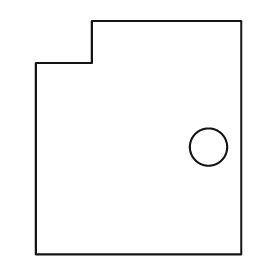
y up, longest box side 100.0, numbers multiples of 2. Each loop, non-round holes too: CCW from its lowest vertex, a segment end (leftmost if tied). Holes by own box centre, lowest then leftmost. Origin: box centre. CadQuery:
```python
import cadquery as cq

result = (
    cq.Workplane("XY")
    .moveTo(-44.0, -50.0)
    .lineTo(44.0, -50.0)
    .lineTo(44.0, 50.0)
    .lineTo(-20.0, 50.0)
    .lineTo(-20.0, 32.0)
    .lineTo(-44.0, 32.0)
    .close()
    .moveTo(30.0, -4.0)
    .circle(8.0)
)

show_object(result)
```